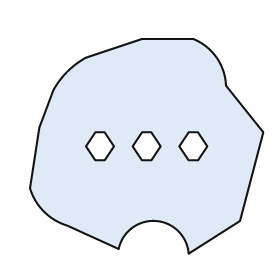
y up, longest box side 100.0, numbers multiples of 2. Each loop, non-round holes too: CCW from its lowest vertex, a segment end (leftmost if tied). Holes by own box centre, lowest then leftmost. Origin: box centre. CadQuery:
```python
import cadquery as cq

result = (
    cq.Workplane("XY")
    .moveTo(18.0, -46.0)
    .lineTo(40.0, -32.0)
    .lineTo(50.0, 6.0)
    .lineTo(34.0, 26.0)
    .threePointArc((30.0, 38.0), (20.0, 46.0))
    .lineTo(-2.0, 46.0)
    .lineTo(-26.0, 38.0)
    .threePointArc((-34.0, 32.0), (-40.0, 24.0))
    .lineTo(-46.0, 8.0)
    .lineTo(-50.0, -18.0)
    .threePointArc((-44.0, -28.0), (-34.0, -34.0))
    .lineTo(-12.0, -44.0)
    .threePointArc((4.0, -32.0), (18.0, -46.0))
    .close()
    .moveTo(-22.0, -6.0)
    .lineTo(-18.0, -6.0)
    .lineTo(-14.0, 0.0)
    .lineTo(-18.0, 6.0)
    .lineTo(-22.0, 6.0)
    .lineTo(-26.0, 0.0)
    .close()
    .moveTo(-2.0, -6.0)
    .lineTo(2.0, -6.0)
    .lineTo(6.0, 0.0)
    .lineTo(2.0, 6.0)
    .lineTo(-2.0, 6.0)
    .lineTo(-6.0, 0.0)
    .close()
    .moveTo(18.0, -6.0)
    .lineTo(22.0, -6.0)
    .lineTo(26.0, 0.0)
    .lineTo(22.0, 6.0)
    .lineTo(18.0, 6.0)
    .lineTo(14.0, 0.0)
    .close()
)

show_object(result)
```